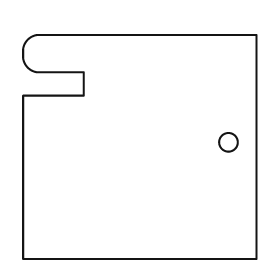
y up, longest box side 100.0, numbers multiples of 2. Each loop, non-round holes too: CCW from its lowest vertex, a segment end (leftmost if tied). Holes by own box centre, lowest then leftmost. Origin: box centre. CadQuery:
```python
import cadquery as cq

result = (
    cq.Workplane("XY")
    .moveTo(-50.0, -48.0)
    .lineTo(50.0, -48.0)
    .lineTo(50.0, 48.0)
    .lineTo(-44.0, 48.0)
    .threePointArc((-48.0, 46.0), (-50.0, 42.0))
    .lineTo(-50.0, 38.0)
    .threePointArc((-48.0, 34.0), (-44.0, 32.0))
    .lineTo(-24.0, 32.0)
    .lineTo(-24.0, 22.0)
    .lineTo(-50.0, 22.0)
    .close()
    .moveTo(38.0, 2.0)
    .circle(4.0)
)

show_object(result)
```